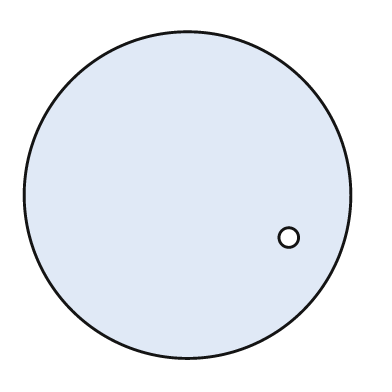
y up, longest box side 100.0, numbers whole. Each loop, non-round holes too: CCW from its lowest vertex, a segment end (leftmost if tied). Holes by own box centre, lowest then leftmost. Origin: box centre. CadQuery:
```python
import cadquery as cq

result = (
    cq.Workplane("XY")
    .moveTo(0.0, 0.0)
    .circle(50.0)
    .moveTo(31.0, -13.0)
    .circle(3.0)
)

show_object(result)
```